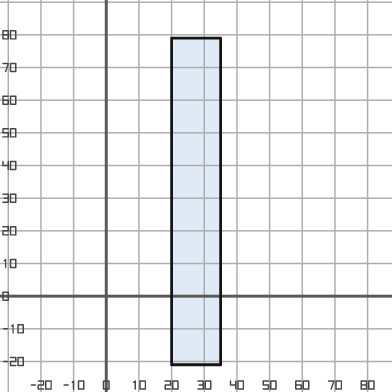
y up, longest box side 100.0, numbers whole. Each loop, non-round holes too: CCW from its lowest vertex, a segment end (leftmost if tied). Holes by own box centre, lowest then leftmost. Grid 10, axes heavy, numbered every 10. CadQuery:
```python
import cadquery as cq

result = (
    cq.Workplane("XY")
    .moveTo(20.0, -21.0)
    .lineTo(35.0, -21.0)
    .lineTo(35.0, 79.0)
    .lineTo(20.0, 79.0)
    .close()
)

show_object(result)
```